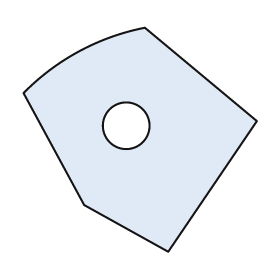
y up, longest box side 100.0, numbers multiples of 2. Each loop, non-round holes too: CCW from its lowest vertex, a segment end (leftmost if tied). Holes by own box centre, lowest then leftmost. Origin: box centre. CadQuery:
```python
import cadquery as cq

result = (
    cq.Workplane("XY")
    .moveTo(12.0, -48.0)
    .lineTo(50.0, 8.0)
    .lineTo(2.0, 48.0)
    .threePointArc((-26.0, 38.0), (-50.0, 20.0))
    .lineTo(-24.0, -28.0)
    .close()
    .moveTo(-6.0, 6.0)
    .circle(10.0)
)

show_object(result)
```